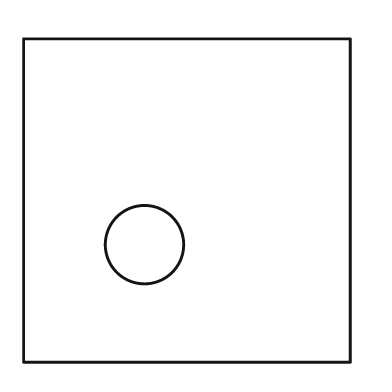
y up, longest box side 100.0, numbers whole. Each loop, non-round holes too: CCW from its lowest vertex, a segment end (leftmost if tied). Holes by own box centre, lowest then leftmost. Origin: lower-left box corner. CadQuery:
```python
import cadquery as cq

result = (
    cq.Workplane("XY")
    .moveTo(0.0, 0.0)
    .lineTo(100.0, 0.0)
    .lineTo(100.0, 99.0)
    .lineTo(0.0, 99.0)
    .close()
    .moveTo(37.0, 36.0)
    .circle(12.0)
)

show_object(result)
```